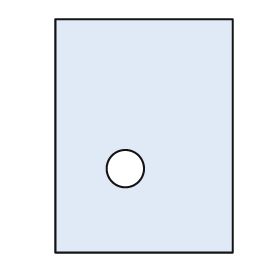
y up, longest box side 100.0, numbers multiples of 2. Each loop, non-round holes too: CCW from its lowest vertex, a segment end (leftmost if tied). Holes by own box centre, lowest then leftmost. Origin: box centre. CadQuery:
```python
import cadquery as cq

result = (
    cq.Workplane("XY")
    .moveTo(-38.0, -50.0)
    .lineTo(38.0, -50.0)
    .lineTo(38.0, 50.0)
    .lineTo(-38.0, 50.0)
    .close()
    .moveTo(-8.0, -14.0)
    .circle(8.0)
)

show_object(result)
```